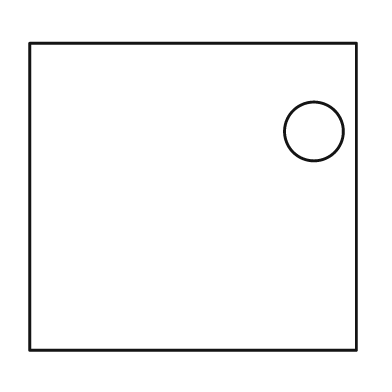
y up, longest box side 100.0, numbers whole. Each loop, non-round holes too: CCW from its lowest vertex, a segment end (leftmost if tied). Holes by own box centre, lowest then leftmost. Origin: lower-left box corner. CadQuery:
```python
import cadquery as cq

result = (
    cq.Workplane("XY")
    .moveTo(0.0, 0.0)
    .lineTo(100.0, 0.0)
    .lineTo(100.0, 94.0)
    .lineTo(0.0, 94.0)
    .close()
    .moveTo(87.0, 67.0)
    .circle(9.0)
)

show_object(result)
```